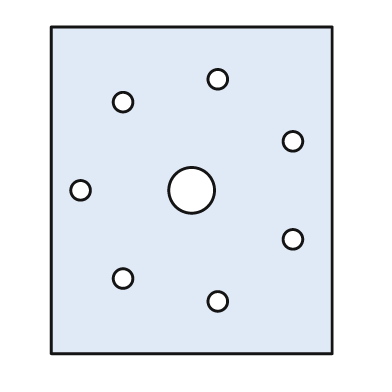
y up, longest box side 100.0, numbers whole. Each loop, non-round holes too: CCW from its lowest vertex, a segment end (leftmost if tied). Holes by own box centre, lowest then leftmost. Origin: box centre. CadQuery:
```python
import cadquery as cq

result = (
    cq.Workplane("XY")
    .moveTo(-43.0, -50.0)
    .lineTo(43.0, -50.0)
    .lineTo(43.0, 50.0)
    .lineTo(-43.0, 50.0)
    .close()
    .moveTo(8.0, -34.0)
    .circle(3.0)
    .moveTo(-21.0, -27.0)
    .circle(3.0)
    .moveTo(31.0, -15.0)
    .circle(3.0)
    .moveTo(-34.0, 0.0)
    .circle(3.0)
    .moveTo(0.0, 0.0)
    .circle(7.0)
    .moveTo(31.0, 15.0)
    .circle(3.0)
    .moveTo(-21.0, 27.0)
    .circle(3.0)
    .moveTo(8.0, 34.0)
    .circle(3.0)
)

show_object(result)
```